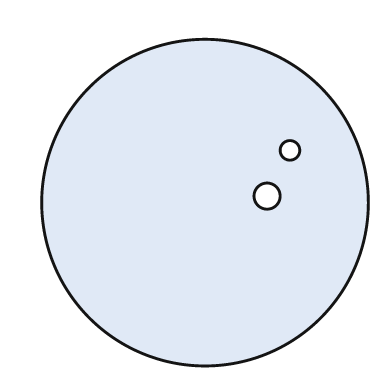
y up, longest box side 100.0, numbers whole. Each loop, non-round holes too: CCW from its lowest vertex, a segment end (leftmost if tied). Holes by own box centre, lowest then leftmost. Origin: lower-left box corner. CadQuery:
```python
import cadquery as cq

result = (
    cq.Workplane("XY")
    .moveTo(50.0, 50.0)
    .circle(50.0)
    .moveTo(69.0, 52.0)
    .circle(4.0)
    .moveTo(76.0, 66.0)
    .circle(3.0)
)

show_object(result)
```